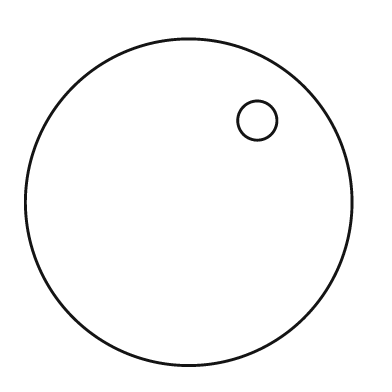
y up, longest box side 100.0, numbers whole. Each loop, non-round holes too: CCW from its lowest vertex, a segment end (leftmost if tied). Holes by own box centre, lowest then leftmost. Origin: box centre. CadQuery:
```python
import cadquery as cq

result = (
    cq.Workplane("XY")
    .moveTo(0.0, 0.0)
    .circle(50.0)
    .moveTo(21.0, 25.0)
    .circle(6.0)
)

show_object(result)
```